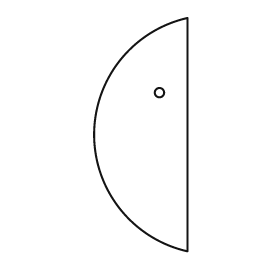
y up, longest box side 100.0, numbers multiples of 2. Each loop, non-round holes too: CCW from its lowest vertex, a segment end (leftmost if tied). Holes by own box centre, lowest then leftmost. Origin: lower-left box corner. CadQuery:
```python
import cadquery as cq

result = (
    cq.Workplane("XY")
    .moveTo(40.0, 0.0)
    .lineTo(40.0, 100.0)
    .threePointArc((0.0, 50.0), (40.0, 0.0))
    .close()
    .moveTo(28.0, 68.0)
    .circle(2.0)
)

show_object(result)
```